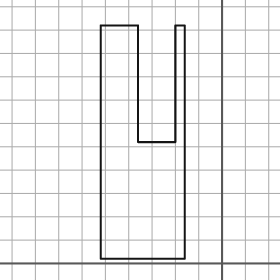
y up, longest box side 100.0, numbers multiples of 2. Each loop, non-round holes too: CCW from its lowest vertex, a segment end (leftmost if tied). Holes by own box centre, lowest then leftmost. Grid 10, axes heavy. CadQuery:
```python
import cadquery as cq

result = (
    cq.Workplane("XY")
    .moveTo(-52.0, 2.0)
    .lineTo(-16.0, 2.0)
    .lineTo(-16.0, 102.0)
    .lineTo(-20.0, 102.0)
    .lineTo(-20.0, 52.0)
    .lineTo(-36.0, 52.0)
    .lineTo(-36.0, 102.0)
    .lineTo(-52.0, 102.0)
    .close()
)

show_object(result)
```